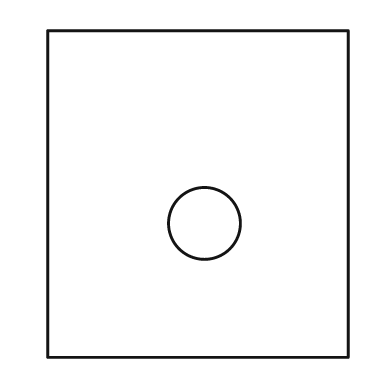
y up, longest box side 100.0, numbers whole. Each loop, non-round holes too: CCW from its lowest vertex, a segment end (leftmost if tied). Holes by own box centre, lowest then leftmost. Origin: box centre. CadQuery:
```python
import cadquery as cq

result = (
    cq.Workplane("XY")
    .moveTo(-46.0, -50.0)
    .lineTo(46.0, -50.0)
    .lineTo(46.0, 50.0)
    .lineTo(-46.0, 50.0)
    .close()
    .moveTo(2.0, -9.0)
    .circle(11.0)
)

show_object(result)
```